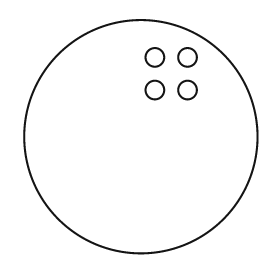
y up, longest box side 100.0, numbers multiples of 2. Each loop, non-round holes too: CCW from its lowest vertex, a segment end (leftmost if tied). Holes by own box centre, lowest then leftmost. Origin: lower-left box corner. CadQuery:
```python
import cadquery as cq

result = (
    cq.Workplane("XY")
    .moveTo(50.0, 50.0)
    .circle(50.0)
    .moveTo(56.0, 70.0)
    .circle(4.0)
    .moveTo(70.0, 70.0)
    .circle(4.0)
    .moveTo(56.0, 84.0)
    .circle(4.0)
    .moveTo(70.0, 84.0)
    .circle(4.0)
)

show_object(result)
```